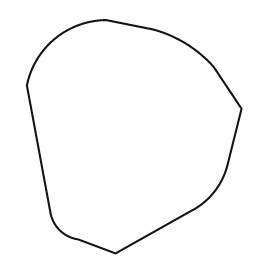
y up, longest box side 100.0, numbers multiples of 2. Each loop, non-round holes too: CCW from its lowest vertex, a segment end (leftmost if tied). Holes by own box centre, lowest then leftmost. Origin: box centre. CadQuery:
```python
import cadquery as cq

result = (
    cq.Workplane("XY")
    .moveTo(-8.0, -50.0)
    .lineTo(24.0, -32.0)
    .threePointArc((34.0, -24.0), (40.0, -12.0))
    .lineTo(46.0, 12.0)
    .lineTo(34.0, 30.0)
    .threePointArc((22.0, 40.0), (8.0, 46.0))
    .lineTo(-12.0, 50.0)
    .threePointArc((-34.0, 42.0), (-46.0, 22.0))
    .lineTo(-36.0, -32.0)
    .threePointArc((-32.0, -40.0), (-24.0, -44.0))
    .close()
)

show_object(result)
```